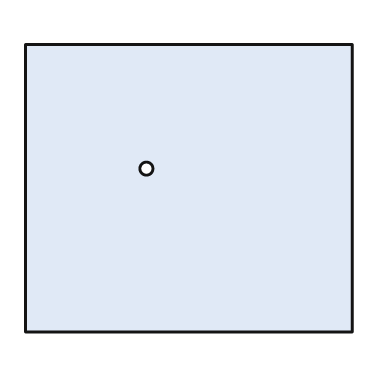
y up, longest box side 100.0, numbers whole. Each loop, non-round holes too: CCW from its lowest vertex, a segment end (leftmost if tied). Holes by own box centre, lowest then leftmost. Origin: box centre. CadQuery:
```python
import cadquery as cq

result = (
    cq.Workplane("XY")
    .moveTo(-50.0, -44.0)
    .lineTo(50.0, -44.0)
    .lineTo(50.0, 44.0)
    .lineTo(-50.0, 44.0)
    .close()
    .moveTo(-13.0, 6.0)
    .circle(2.0)
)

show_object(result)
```